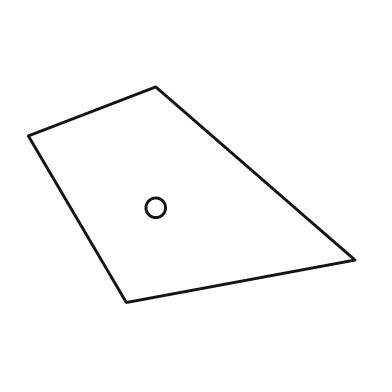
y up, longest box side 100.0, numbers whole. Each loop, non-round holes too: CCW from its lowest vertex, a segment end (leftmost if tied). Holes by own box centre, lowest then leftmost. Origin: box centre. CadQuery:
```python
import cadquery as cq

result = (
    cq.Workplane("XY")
    .moveTo(-20.0, -33.0)
    .lineTo(50.0, -20.0)
    .lineTo(-11.0, 33.0)
    .lineTo(-50.0, 18.0)
    .close()
    .moveTo(-11.0, -4.0)
    .circle(3.0)
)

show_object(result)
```